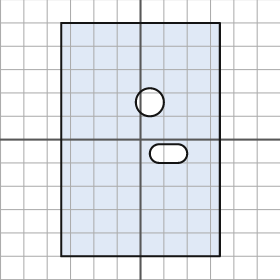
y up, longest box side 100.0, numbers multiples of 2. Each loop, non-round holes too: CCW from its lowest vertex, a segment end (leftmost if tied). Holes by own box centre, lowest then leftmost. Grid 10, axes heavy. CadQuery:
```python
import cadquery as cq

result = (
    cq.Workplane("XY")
    .moveTo(-34.0, -50.0)
    .lineTo(34.0, -50.0)
    .lineTo(34.0, 50.0)
    .lineTo(-34.0, 50.0)
    .close()
    .moveTo(8.0, -10.0)
    .lineTo(16.0, -10.0)
    .threePointArc((20.0, -6.0), (16.0, -2.0))
    .lineTo(8.0, -2.0)
    .threePointArc((4.0, -6.0), (8.0, -10.0))
    .close()
    .moveTo(4.0, 16.0)
    .circle(6.0)
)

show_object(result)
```